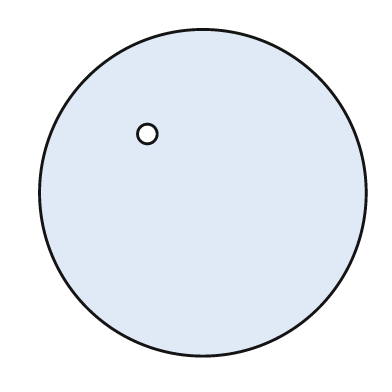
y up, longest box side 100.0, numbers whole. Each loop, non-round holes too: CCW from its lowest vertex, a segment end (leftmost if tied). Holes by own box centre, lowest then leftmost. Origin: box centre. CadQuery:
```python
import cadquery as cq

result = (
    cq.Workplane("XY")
    .moveTo(0.0, 0.0)
    .circle(50.0)
    .moveTo(-17.0, 18.0)
    .circle(3.0)
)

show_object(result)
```